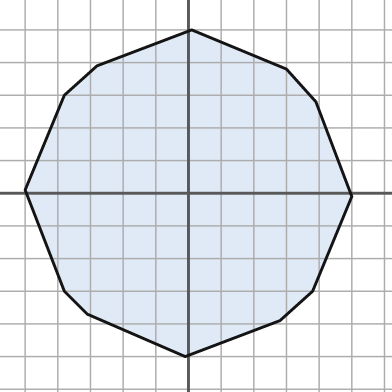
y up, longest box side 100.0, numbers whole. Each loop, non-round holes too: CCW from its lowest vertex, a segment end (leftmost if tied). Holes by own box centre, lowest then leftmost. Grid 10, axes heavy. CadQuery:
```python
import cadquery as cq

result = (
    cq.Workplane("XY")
    .moveTo(-1.0, -50.0)
    .lineTo(28.0, -39.0)
    .lineTo(38.0, -30.0)
    .lineTo(50.0, -1.0)
    .lineTo(39.0, 28.0)
    .lineTo(30.0, 38.0)
    .lineTo(1.0, 50.0)
    .lineTo(-28.0, 39.0)
    .lineTo(-38.0, 30.0)
    .lineTo(-50.0, 1.0)
    .lineTo(-38.0, -30.0)
    .lineTo(-31.0, -37.0)
    .close()
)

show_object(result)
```